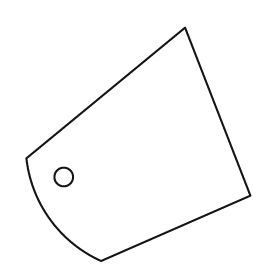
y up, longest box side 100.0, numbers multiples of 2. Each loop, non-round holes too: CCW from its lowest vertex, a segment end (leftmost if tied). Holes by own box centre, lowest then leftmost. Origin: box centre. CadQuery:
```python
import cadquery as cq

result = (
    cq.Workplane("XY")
    .moveTo(-16.0, -50.0)
    .lineTo(48.0, -22.0)
    .lineTo(20.0, 50.0)
    .lineTo(-48.0, -6.0)
    .threePointArc((-38.0, -32.0), (-16.0, -50.0))
    .close()
    .moveTo(-32.0, -14.0)
    .circle(4.0)
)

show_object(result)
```